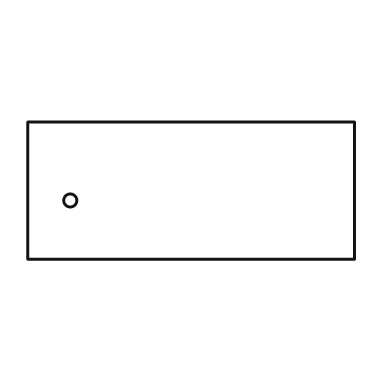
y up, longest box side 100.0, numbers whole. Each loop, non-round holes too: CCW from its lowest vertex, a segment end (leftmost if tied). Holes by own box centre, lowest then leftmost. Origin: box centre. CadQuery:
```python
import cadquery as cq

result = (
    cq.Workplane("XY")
    .moveTo(-50.0, -21.0)
    .lineTo(50.0, -21.0)
    .lineTo(50.0, 21.0)
    .lineTo(-50.0, 21.0)
    .close()
    .moveTo(-37.0, -3.0)
    .circle(2.0)
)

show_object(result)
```